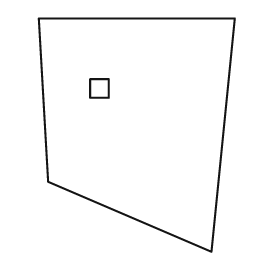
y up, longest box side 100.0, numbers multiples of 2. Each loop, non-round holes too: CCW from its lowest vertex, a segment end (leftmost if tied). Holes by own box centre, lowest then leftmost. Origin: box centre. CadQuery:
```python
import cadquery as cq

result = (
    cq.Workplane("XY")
    .moveTo(32.0, -50.0)
    .lineTo(42.0, 50.0)
    .lineTo(-42.0, 50.0)
    .lineTo(-38.0, -20.0)
    .close()
    .moveTo(-20.0, 16.0)
    .lineTo(-12.0, 16.0)
    .lineTo(-12.0, 24.0)
    .lineTo(-20.0, 24.0)
    .close()
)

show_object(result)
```